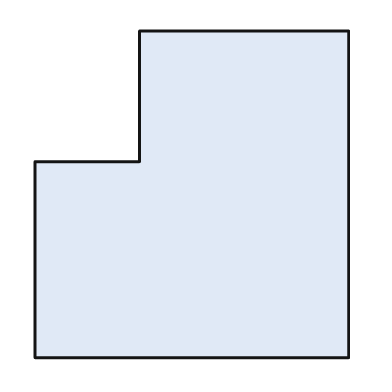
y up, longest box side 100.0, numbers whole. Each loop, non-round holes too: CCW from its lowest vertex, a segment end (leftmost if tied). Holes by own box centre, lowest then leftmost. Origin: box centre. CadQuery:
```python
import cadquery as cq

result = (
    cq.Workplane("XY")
    .moveTo(-48.0, -50.0)
    .lineTo(48.0, -50.0)
    .lineTo(48.0, 50.0)
    .lineTo(-16.0, 50.0)
    .lineTo(-16.0, 10.0)
    .lineTo(-48.0, 10.0)
    .close()
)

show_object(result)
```